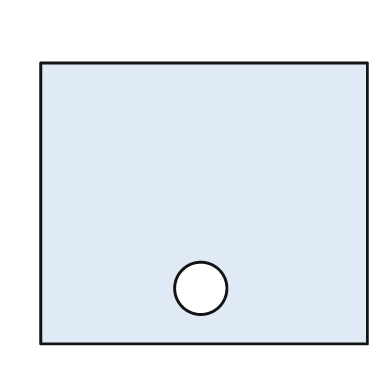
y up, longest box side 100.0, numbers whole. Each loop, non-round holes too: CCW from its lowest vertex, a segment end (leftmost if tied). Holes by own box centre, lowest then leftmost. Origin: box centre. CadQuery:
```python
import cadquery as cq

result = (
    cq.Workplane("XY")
    .moveTo(-50.0, -43.0)
    .lineTo(50.0, -43.0)
    .lineTo(50.0, 43.0)
    .lineTo(-50.0, 43.0)
    .close()
    .moveTo(-1.0, -26.0)
    .circle(8.0)
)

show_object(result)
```